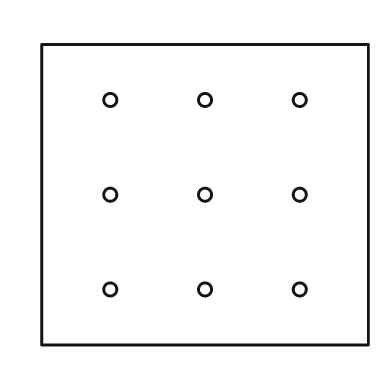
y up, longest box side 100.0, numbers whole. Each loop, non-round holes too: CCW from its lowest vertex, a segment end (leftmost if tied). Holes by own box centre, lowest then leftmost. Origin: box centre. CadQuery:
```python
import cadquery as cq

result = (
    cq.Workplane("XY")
    .moveTo(-50.0, -46.0)
    .lineTo(50.0, -46.0)
    .lineTo(50.0, 46.0)
    .lineTo(-50.0, 46.0)
    .close()
    .moveTo(-29.0, -29.0)
    .circle(2.0)
    .moveTo(0.0, -29.0)
    .circle(2.0)
    .moveTo(29.0, -29.0)
    .circle(2.0)
    .moveTo(-29.0, 0.0)
    .circle(2.0)
    .moveTo(0.0, 0.0)
    .circle(2.0)
    .moveTo(29.0, 0.0)
    .circle(2.0)
    .moveTo(-29.0, 29.0)
    .circle(2.0)
    .moveTo(0.0, 29.0)
    .circle(2.0)
    .moveTo(29.0, 29.0)
    .circle(2.0)
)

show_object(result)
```